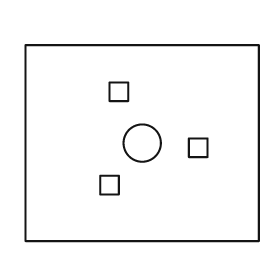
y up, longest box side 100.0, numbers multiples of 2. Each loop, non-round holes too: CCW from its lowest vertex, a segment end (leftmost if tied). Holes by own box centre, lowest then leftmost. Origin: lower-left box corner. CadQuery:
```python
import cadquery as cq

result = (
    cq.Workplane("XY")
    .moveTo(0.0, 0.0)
    .lineTo(100.0, 0.0)
    .lineTo(100.0, 84.0)
    .lineTo(0.0, 84.0)
    .close()
    .moveTo(32.0, 20.0)
    .lineTo(40.0, 20.0)
    .lineTo(40.0, 28.0)
    .lineTo(32.0, 28.0)
    .close()
    .moveTo(70.0, 36.0)
    .lineTo(78.0, 36.0)
    .lineTo(78.0, 44.0)
    .lineTo(70.0, 44.0)
    .close()
    .moveTo(50.0, 42.0)
    .circle(8.0)
    .moveTo(36.0, 60.0)
    .lineTo(44.0, 60.0)
    .lineTo(44.0, 68.0)
    .lineTo(36.0, 68.0)
    .close()
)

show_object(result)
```